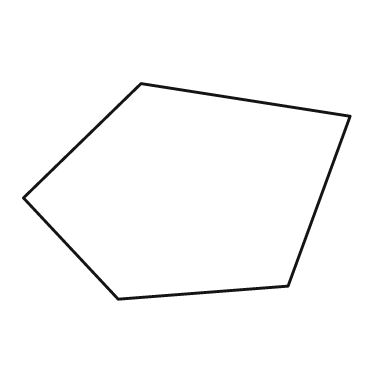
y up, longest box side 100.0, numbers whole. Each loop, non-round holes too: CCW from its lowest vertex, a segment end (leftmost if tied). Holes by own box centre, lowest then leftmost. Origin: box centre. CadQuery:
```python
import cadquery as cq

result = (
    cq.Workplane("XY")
    .moveTo(-21.0, -33.0)
    .lineTo(31.0, -29.0)
    .lineTo(50.0, 23.0)
    .lineTo(-14.0, 33.0)
    .lineTo(-50.0, -2.0)
    .close()
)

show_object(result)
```